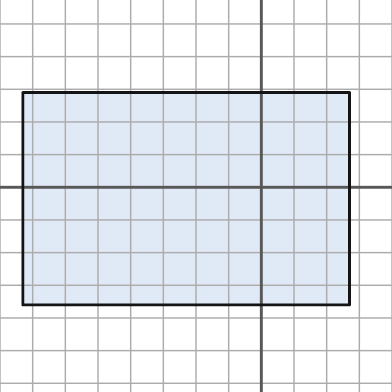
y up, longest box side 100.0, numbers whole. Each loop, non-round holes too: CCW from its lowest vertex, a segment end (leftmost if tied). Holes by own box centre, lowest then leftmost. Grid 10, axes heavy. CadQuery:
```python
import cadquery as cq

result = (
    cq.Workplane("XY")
    .moveTo(-73.0, -36.0)
    .lineTo(27.0, -36.0)
    .lineTo(27.0, 29.0)
    .lineTo(-73.0, 29.0)
    .close()
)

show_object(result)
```